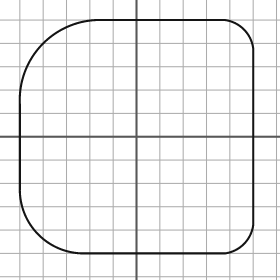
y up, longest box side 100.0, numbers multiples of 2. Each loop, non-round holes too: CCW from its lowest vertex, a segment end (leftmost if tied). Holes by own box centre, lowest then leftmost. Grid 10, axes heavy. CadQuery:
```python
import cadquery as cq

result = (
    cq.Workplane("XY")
    .moveTo(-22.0, -50.0)
    .lineTo(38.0, -50.0)
    .threePointArc((46.0, -46.0), (50.0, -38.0))
    .lineTo(50.0, 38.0)
    .threePointArc((46.0, 46.0), (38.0, 50.0))
    .lineTo(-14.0, 50.0)
    .threePointArc((-40.0, 40.0), (-50.0, 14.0))
    .lineTo(-50.0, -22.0)
    .threePointArc((-42.0, -42.0), (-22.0, -50.0))
    .close()
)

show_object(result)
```